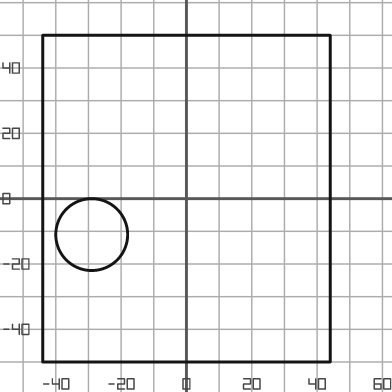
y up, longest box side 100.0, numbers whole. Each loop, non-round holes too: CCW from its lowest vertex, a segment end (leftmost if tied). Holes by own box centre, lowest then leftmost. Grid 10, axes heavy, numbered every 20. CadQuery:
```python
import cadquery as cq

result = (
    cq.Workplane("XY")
    .moveTo(-44.0, -50.0)
    .lineTo(44.0, -50.0)
    .lineTo(44.0, 50.0)
    .lineTo(-44.0, 50.0)
    .close()
    .moveTo(-29.0, -11.0)
    .circle(11.0)
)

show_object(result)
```